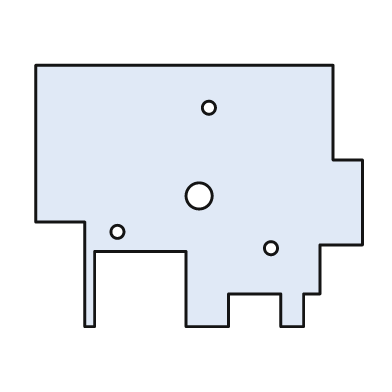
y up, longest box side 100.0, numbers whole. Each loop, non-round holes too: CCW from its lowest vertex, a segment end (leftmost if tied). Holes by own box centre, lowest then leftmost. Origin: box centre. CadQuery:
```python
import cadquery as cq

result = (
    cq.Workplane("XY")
    .moveTo(-35.0, -40.0)
    .lineTo(-32.0, -40.0)
    .lineTo(-32.0, -17.0)
    .lineTo(-4.0, -17.0)
    .lineTo(-4.0, -40.0)
    .lineTo(9.0, -40.0)
    .lineTo(9.0, -30.0)
    .lineTo(25.0, -30.0)
    .lineTo(25.0, -40.0)
    .lineTo(32.0, -40.0)
    .lineTo(32.0, -30.0)
    .lineTo(37.0, -30.0)
    .lineTo(37.0, -15.0)
    .lineTo(50.0, -15.0)
    .lineTo(50.0, 11.0)
    .lineTo(41.0, 11.0)
    .lineTo(41.0, 40.0)
    .lineTo(-50.0, 40.0)
    .lineTo(-50.0, -8.0)
    .lineTo(-35.0, -8.0)
    .close()
    .moveTo(22.0, -16.0)
    .circle(2.0)
    .moveTo(-25.0, -11.0)
    .circle(2.0)
    .moveTo(0.0, 0.0)
    .circle(4.0)
    .moveTo(3.0, 27.0)
    .circle(2.0)
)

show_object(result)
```